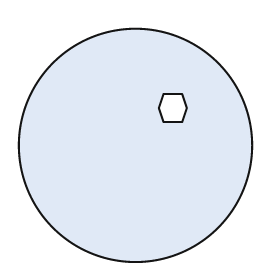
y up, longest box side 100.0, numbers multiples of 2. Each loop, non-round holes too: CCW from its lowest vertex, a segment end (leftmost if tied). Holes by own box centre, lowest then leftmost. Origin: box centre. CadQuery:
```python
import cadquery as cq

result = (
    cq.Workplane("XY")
    .moveTo(0.0, 0.0)
    .circle(50.0)
    .moveTo(12.0, 10.0)
    .lineTo(20.0, 10.0)
    .lineTo(22.0, 16.0)
    .lineTo(20.0, 22.0)
    .lineTo(12.0, 22.0)
    .lineTo(10.0, 16.0)
    .close()
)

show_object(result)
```